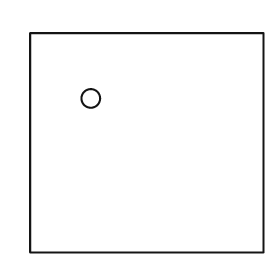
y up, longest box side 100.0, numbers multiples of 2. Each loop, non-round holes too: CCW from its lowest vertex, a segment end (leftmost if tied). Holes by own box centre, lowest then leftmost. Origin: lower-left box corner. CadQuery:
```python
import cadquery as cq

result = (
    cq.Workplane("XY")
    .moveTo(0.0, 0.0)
    .lineTo(100.0, 0.0)
    .lineTo(100.0, 94.0)
    .lineTo(0.0, 94.0)
    .close()
    .moveTo(26.0, 66.0)
    .circle(4.0)
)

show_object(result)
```